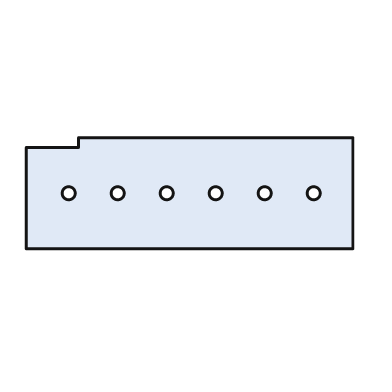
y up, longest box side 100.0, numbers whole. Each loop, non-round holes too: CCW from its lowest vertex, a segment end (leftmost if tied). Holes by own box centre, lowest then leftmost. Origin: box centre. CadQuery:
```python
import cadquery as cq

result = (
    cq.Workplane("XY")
    .moveTo(-50.0, -17.0)
    .lineTo(50.0, -17.0)
    .lineTo(50.0, 17.0)
    .lineTo(-34.0, 17.0)
    .lineTo(-34.0, 14.0)
    .lineTo(-50.0, 14.0)
    .close()
    .moveTo(-37.0, 0.0)
    .circle(2.0)
    .moveTo(-22.0, 0.0)
    .circle(2.0)
    .moveTo(-7.0, 0.0)
    .circle(2.0)
    .moveTo(8.0, 0.0)
    .circle(2.0)
    .moveTo(23.0, 0.0)
    .circle(2.0)
    .moveTo(38.0, 0.0)
    .circle(2.0)
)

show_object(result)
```